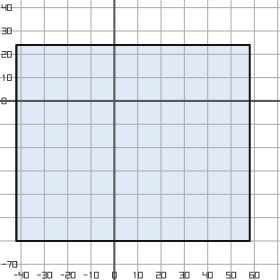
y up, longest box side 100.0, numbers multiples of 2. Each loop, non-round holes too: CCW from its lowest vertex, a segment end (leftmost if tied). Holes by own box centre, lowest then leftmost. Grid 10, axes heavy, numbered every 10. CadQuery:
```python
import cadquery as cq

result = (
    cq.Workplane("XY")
    .moveTo(-42.0, -60.0)
    .lineTo(58.0, -60.0)
    .lineTo(58.0, 24.0)
    .lineTo(-42.0, 24.0)
    .close()
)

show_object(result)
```